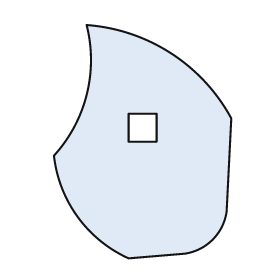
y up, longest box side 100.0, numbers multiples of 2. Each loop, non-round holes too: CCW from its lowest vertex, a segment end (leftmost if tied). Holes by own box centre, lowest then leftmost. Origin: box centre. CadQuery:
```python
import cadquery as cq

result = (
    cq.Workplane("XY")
    .moveTo(-6.0, -50.0)
    .lineTo(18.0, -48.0)
    .threePointArc((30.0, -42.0), (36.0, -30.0))
    .lineTo(38.0, 10.0)
    .threePointArc((12.0, 38.0), (-24.0, 50.0))
    .threePointArc((-24.0, 20.0), (-38.0, -6.0))
    .threePointArc((-28.0, -32.0), (-6.0, -50.0))
    .close()
    .moveTo(-6.0, 0.0)
    .lineTo(6.0, 0.0)
    .lineTo(6.0, 12.0)
    .lineTo(-6.0, 12.0)
    .close()
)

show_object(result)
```